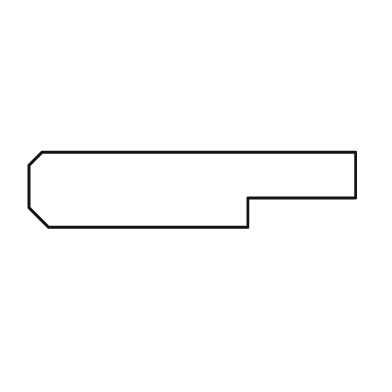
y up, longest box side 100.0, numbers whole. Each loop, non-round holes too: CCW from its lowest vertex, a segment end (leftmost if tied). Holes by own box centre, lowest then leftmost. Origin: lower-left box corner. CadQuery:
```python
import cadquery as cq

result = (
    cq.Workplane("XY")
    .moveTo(6.0, 0.0)
    .lineTo(67.0, 0.0)
    .lineTo(67.0, 9.0)
    .lineTo(100.0, 9.0)
    .lineTo(100.0, 23.0)
    .lineTo(4.0, 23.0)
    .lineTo(0.0, 19.0)
    .lineTo(0.0, 6.0)
    .close()
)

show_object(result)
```